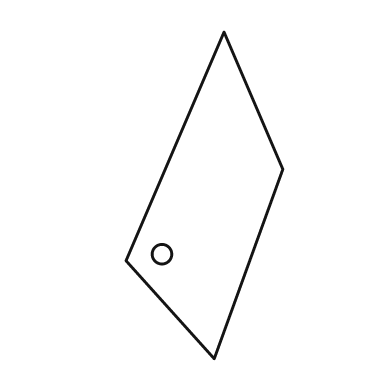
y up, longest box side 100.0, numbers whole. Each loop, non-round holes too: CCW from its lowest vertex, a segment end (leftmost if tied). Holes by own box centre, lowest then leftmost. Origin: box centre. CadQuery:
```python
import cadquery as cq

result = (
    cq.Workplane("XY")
    .moveTo(3.0, -50.0)
    .lineTo(24.0, 8.0)
    .lineTo(6.0, 50.0)
    .lineTo(-24.0, -20.0)
    .close()
    .moveTo(-13.0, -18.0)
    .circle(3.0)
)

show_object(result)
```